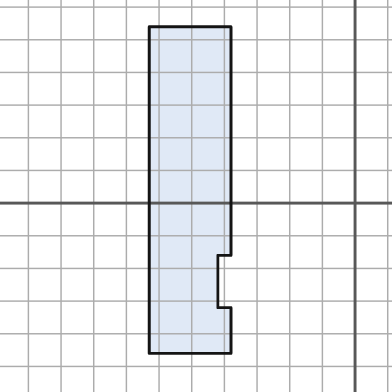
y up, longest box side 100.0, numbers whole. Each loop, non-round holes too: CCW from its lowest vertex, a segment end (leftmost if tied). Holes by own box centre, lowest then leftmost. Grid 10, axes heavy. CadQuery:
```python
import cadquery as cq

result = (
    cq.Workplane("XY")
    .moveTo(-63.0, -46.0)
    .lineTo(-38.0, -46.0)
    .lineTo(-38.0, -32.0)
    .lineTo(-42.0, -32.0)
    .lineTo(-42.0, -16.0)
    .lineTo(-38.0, -16.0)
    .lineTo(-38.0, 54.0)
    .lineTo(-63.0, 54.0)
    .close()
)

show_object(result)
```